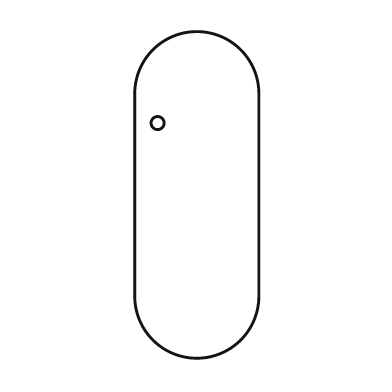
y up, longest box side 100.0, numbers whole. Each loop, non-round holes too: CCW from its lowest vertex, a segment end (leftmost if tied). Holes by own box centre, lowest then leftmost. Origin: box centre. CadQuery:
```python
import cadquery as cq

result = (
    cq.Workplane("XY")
    .moveTo(-19.0, -31.0)
    .threePointArc((0.0, -50.0), (19.0, -31.0))
    .lineTo(19.0, 31.0)
    .threePointArc((0.0, 50.0), (-19.0, 31.0))
    .close()
    .moveTo(-12.0, 22.0)
    .circle(2.0)
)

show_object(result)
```